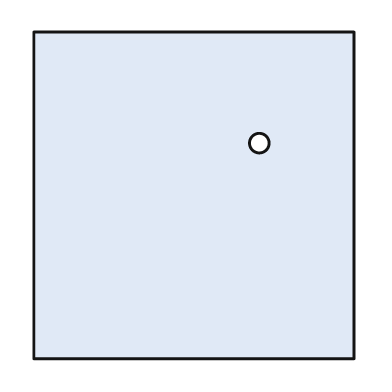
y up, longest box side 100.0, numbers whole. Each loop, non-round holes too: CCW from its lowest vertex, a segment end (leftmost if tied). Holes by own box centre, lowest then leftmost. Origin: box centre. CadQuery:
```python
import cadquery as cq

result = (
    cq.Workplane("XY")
    .moveTo(-49.0, -50.0)
    .lineTo(49.0, -50.0)
    .lineTo(49.0, 50.0)
    .lineTo(-49.0, 50.0)
    .close()
    .moveTo(20.0, 16.0)
    .circle(3.0)
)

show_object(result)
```